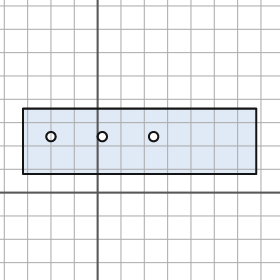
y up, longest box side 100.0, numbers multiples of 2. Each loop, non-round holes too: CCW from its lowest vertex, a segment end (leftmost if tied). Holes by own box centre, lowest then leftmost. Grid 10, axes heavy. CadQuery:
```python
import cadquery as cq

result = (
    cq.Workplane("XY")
    .moveTo(-32.0, 8.0)
    .lineTo(68.0, 8.0)
    .lineTo(68.0, 36.0)
    .lineTo(-32.0, 36.0)
    .close()
    .moveTo(-20.0, 24.0)
    .circle(2.0)
    .moveTo(2.0, 24.0)
    .circle(2.0)
    .moveTo(24.0, 24.0)
    .circle(2.0)
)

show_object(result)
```